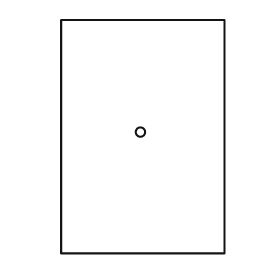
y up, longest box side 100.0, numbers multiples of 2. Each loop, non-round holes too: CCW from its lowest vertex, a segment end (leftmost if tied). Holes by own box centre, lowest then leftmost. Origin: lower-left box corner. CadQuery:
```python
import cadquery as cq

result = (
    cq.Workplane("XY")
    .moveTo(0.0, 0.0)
    .lineTo(70.0, 0.0)
    .lineTo(70.0, 100.0)
    .lineTo(0.0, 100.0)
    .close()
    .moveTo(34.0, 52.0)
    .circle(2.0)
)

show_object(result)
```